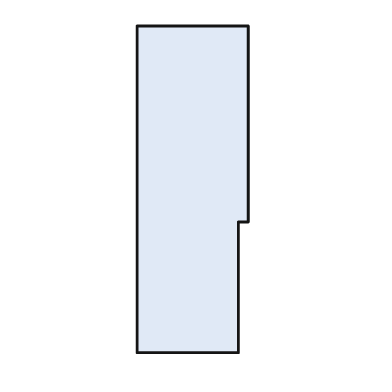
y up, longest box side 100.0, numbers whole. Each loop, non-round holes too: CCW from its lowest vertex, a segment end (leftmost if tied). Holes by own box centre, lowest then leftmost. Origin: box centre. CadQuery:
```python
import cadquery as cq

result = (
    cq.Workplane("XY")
    .moveTo(-17.0, -50.0)
    .lineTo(14.0, -50.0)
    .lineTo(14.0, -10.0)
    .lineTo(17.0, -10.0)
    .lineTo(17.0, 50.0)
    .lineTo(-17.0, 50.0)
    .close()
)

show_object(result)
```